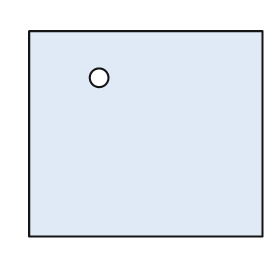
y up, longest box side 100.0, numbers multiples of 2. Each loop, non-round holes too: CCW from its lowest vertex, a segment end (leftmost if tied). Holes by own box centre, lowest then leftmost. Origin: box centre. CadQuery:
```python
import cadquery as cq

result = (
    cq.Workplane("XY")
    .moveTo(-50.0, -44.0)
    .lineTo(50.0, -44.0)
    .lineTo(50.0, 44.0)
    .lineTo(-50.0, 44.0)
    .close()
    .moveTo(-20.0, 24.0)
    .circle(4.0)
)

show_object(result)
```